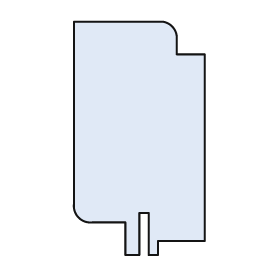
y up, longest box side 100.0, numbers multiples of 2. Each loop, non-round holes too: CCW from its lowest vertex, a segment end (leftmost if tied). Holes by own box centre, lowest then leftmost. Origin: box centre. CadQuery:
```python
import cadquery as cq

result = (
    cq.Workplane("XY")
    .moveTo(-6.0, -50.0)
    .lineTo(0.0, -50.0)
    .lineTo(0.0, -32.0)
    .lineTo(4.0, -32.0)
    .lineTo(4.0, -50.0)
    .lineTo(8.0, -50.0)
    .lineTo(8.0, -44.0)
    .lineTo(28.0, -44.0)
    .lineTo(28.0, 36.0)
    .lineTo(16.0, 36.0)
    .lineTo(16.0, 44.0)
    .threePointArc((14.0, 48.0), (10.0, 50.0))
    .lineTo(-28.0, 50.0)
    .lineTo(-28.0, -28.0)
    .threePointArc((-26.0, -34.0), (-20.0, -36.0))
    .lineTo(-6.0, -36.0)
    .close()
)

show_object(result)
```